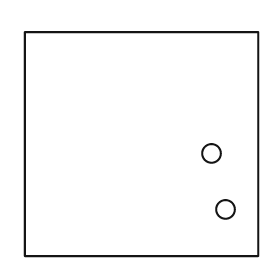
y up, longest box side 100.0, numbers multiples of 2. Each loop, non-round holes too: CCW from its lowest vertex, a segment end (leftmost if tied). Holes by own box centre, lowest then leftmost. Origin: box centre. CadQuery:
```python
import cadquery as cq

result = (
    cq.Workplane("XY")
    .moveTo(-50.0, -48.0)
    .lineTo(50.0, -48.0)
    .lineTo(50.0, 48.0)
    .lineTo(-50.0, 48.0)
    .close()
    .moveTo(36.0, -28.0)
    .circle(4.0)
    .moveTo(30.0, -4.0)
    .circle(4.0)
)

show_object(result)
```